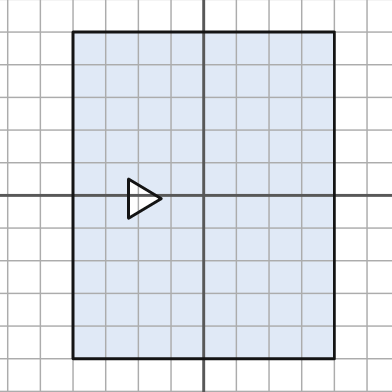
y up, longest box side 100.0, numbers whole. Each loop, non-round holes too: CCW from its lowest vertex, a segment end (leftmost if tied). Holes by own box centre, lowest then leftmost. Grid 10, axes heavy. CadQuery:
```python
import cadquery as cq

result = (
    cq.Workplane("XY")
    .moveTo(-40.0, -50.0)
    .lineTo(40.0, -50.0)
    .lineTo(40.0, 50.0)
    .lineTo(-40.0, 50.0)
    .close()
    .moveTo(-23.0, -7.0)
    .lineTo(-13.0, -1.0)
    .lineTo(-23.0, 5.0)
    .close()
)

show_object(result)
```